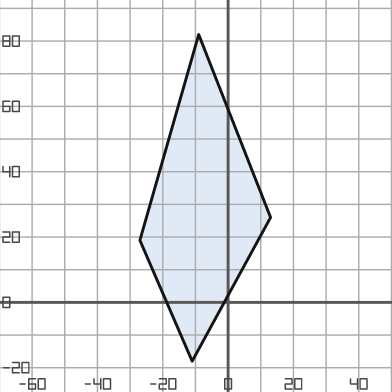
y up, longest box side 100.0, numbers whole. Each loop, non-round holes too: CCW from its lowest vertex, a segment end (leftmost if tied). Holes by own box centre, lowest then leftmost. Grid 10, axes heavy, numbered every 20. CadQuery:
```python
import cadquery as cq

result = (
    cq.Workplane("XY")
    .moveTo(-11.0, -18.0)
    .lineTo(13.0, 26.0)
    .lineTo(-9.0, 82.0)
    .lineTo(-27.0, 19.0)
    .close()
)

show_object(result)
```